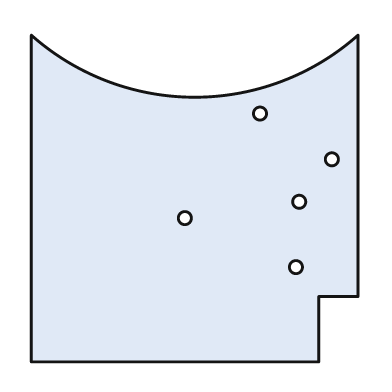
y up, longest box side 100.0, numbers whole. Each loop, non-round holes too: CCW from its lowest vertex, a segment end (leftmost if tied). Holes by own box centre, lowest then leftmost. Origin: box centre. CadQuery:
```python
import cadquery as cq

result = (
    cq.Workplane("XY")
    .moveTo(-50.0, -50.0)
    .lineTo(38.0, -50.0)
    .lineTo(38.0, -30.0)
    .lineTo(50.0, -30.0)
    .lineTo(50.0, 50.0)
    .threePointArc((0.0, 31.0), (-50.0, 50.0))
    .close()
    .moveTo(31.0, -21.0)
    .circle(2.0)
    .moveTo(-3.0, -6.0)
    .circle(2.0)
    .moveTo(32.0, -1.0)
    .circle(2.0)
    .moveTo(42.0, 12.0)
    .circle(2.0)
    .moveTo(20.0, 26.0)
    .circle(2.0)
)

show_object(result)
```